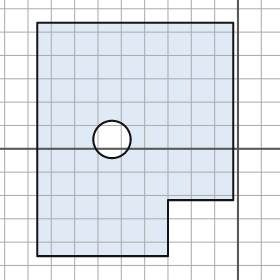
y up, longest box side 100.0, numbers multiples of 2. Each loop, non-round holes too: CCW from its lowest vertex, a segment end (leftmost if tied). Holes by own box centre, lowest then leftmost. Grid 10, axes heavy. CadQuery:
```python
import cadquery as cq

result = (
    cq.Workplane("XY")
    .moveTo(-86.0, -46.0)
    .lineTo(-30.0, -46.0)
    .lineTo(-30.0, -22.0)
    .lineTo(-2.0, -22.0)
    .lineTo(-2.0, 54.0)
    .lineTo(-86.0, 54.0)
    .close()
    .moveTo(-54.0, 4.0)
    .circle(8.0)
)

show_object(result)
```